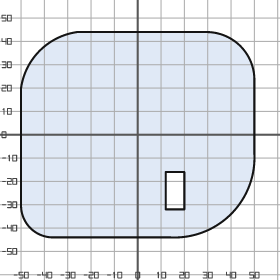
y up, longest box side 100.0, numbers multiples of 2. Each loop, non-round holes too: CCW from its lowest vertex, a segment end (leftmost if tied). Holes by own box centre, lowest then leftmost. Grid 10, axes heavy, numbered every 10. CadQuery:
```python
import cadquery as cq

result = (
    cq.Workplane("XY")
    .moveTo(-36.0, -44.0)
    .lineTo(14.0, -44.0)
    .threePointArc((40.0, -34.0), (50.0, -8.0))
    .lineTo(50.0, 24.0)
    .threePointArc((44.0, 38.0), (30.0, 44.0))
    .lineTo(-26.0, 44.0)
    .threePointArc((-42.0, 36.0), (-50.0, 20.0))
    .lineTo(-50.0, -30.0)
    .threePointArc((-46.0, -40.0), (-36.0, -44.0))
    .close()
    .moveTo(12.0, -32.0)
    .lineTo(20.0, -32.0)
    .lineTo(20.0, -16.0)
    .lineTo(12.0, -16.0)
    .close()
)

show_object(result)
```